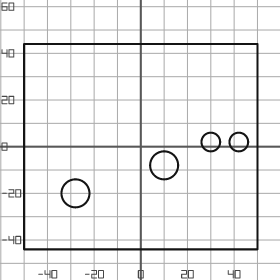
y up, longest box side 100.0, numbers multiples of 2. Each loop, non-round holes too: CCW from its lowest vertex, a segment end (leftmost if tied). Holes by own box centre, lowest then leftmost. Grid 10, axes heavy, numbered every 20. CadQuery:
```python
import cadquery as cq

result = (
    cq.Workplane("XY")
    .moveTo(-50.0, -44.0)
    .lineTo(50.0, -44.0)
    .lineTo(50.0, 44.0)
    .lineTo(-50.0, 44.0)
    .close()
    .moveTo(-28.0, -20.0)
    .circle(6.0)
    .moveTo(10.0, -8.0)
    .circle(6.0)
    .moveTo(30.0, 2.0)
    .circle(4.0)
    .moveTo(42.0, 2.0)
    .circle(4.0)
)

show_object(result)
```